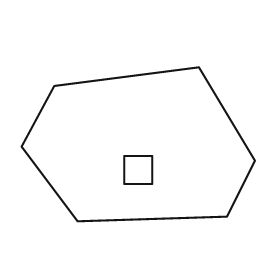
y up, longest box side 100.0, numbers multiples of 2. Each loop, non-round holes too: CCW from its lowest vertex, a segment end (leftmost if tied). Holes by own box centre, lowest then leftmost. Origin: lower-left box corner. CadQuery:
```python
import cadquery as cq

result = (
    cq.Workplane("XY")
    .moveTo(24.0, 0.0)
    .lineTo(88.0, 2.0)
    .lineTo(100.0, 26.0)
    .lineTo(76.0, 66.0)
    .lineTo(14.0, 58.0)
    .lineTo(0.0, 32.0)
    .close()
    .moveTo(44.0, 16.0)
    .lineTo(56.0, 16.0)
    .lineTo(56.0, 28.0)
    .lineTo(44.0, 28.0)
    .close()
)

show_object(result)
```